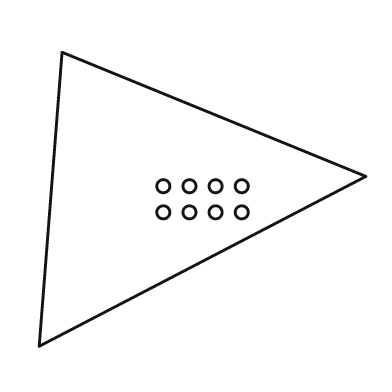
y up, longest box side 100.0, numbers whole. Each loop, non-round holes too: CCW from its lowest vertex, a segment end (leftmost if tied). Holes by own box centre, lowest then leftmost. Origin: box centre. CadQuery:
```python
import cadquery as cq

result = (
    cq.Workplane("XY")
    .moveTo(-50.0, -45.0)
    .lineTo(50.0, 7.0)
    .lineTo(-43.0, 45.0)
    .close()
    .moveTo(-12.0, -4.0)
    .circle(2.0)
    .moveTo(-4.0, -4.0)
    .circle(2.0)
    .moveTo(4.0, -4.0)
    .circle(2.0)
    .moveTo(12.0, -4.0)
    .circle(2.0)
    .moveTo(-12.0, 4.0)
    .circle(2.0)
    .moveTo(-4.0, 4.0)
    .circle(2.0)
    .moveTo(4.0, 4.0)
    .circle(2.0)
    .moveTo(12.0, 4.0)
    .circle(2.0)
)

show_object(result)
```